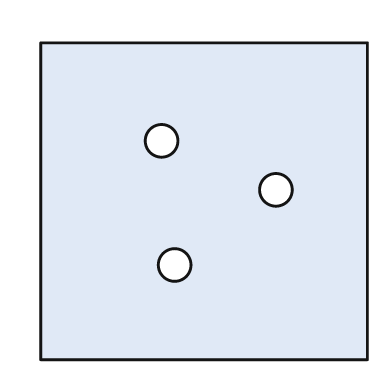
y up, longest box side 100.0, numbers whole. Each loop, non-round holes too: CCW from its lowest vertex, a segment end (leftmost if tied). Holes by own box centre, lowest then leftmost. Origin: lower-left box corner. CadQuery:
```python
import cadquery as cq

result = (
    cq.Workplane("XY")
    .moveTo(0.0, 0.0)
    .lineTo(100.0, 0.0)
    .lineTo(100.0, 97.0)
    .lineTo(0.0, 97.0)
    .close()
    .moveTo(41.0, 29.0)
    .circle(5.0)
    .moveTo(72.0, 52.0)
    .circle(5.0)
    .moveTo(37.0, 67.0)
    .circle(5.0)
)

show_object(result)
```